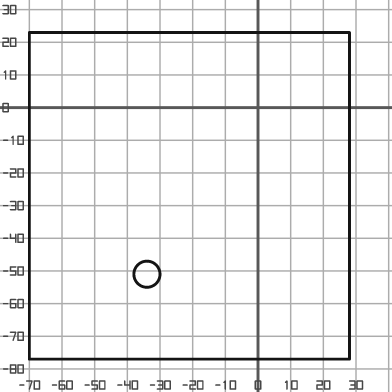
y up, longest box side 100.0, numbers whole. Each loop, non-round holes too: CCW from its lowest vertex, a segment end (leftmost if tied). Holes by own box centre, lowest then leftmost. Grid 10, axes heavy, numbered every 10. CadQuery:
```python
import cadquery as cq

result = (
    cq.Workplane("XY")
    .moveTo(-70.0, -77.0)
    .lineTo(28.0, -77.0)
    .lineTo(28.0, 23.0)
    .lineTo(-70.0, 23.0)
    .close()
    .moveTo(-34.0, -51.0)
    .circle(4.0)
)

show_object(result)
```